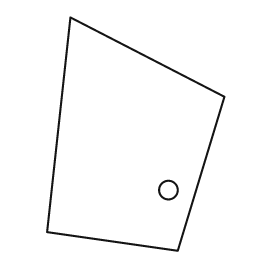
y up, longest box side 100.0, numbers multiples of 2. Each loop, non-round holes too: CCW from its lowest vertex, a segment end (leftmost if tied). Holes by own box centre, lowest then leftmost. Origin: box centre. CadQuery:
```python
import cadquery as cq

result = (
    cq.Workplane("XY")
    .moveTo(18.0, -50.0)
    .lineTo(38.0, 16.0)
    .lineTo(-28.0, 50.0)
    .lineTo(-38.0, -42.0)
    .close()
    .moveTo(14.0, -24.0)
    .circle(4.0)
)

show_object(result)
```